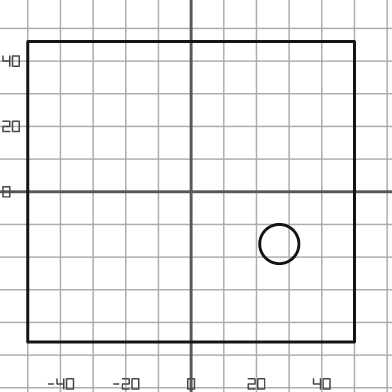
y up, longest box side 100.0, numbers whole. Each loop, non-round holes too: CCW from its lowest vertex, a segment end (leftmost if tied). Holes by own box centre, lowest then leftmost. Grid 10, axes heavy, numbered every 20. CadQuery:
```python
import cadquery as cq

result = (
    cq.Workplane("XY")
    .moveTo(-50.0, -46.0)
    .lineTo(50.0, -46.0)
    .lineTo(50.0, 46.0)
    .lineTo(-50.0, 46.0)
    .close()
    .moveTo(27.0, -16.0)
    .circle(6.0)
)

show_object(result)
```